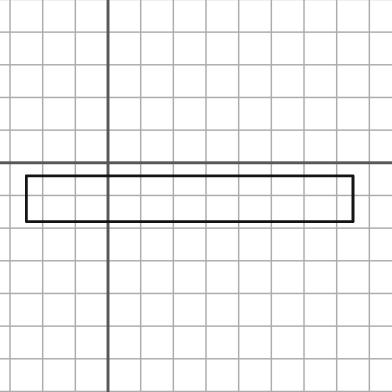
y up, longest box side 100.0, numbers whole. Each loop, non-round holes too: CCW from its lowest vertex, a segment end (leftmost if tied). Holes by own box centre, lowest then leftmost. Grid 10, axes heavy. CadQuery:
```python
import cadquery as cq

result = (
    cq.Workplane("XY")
    .moveTo(-25.0, -18.0)
    .lineTo(75.0, -18.0)
    .lineTo(75.0, -4.0)
    .lineTo(-25.0, -4.0)
    .close()
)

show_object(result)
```